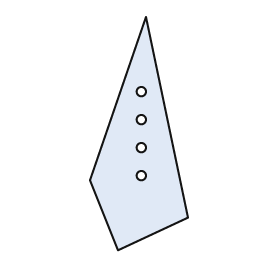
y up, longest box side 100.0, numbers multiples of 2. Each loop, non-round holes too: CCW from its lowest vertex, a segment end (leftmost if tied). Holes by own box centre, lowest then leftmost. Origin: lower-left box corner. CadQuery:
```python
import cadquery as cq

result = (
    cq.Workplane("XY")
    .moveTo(12.0, 0.0)
    .lineTo(42.0, 14.0)
    .lineTo(24.0, 100.0)
    .lineTo(0.0, 30.0)
    .close()
    .moveTo(22.0, 32.0)
    .circle(2.0)
    .moveTo(22.0, 44.0)
    .circle(2.0)
    .moveTo(22.0, 56.0)
    .circle(2.0)
    .moveTo(22.0, 68.0)
    .circle(2.0)
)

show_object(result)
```